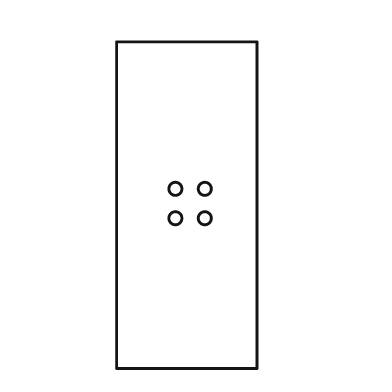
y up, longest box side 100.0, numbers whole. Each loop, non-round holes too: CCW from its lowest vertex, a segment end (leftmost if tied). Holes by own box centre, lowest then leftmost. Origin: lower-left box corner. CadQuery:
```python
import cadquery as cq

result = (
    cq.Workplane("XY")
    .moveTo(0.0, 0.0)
    .lineTo(43.0, 0.0)
    .lineTo(43.0, 100.0)
    .lineTo(0.0, 100.0)
    .close()
    .moveTo(18.0, 46.0)
    .circle(2.0)
    .moveTo(27.0, 46.0)
    .circle(2.0)
    .moveTo(18.0, 55.0)
    .circle(2.0)
    .moveTo(27.0, 55.0)
    .circle(2.0)
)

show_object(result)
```